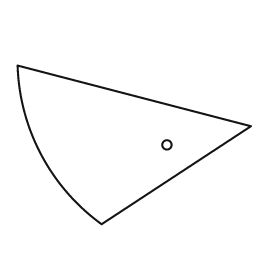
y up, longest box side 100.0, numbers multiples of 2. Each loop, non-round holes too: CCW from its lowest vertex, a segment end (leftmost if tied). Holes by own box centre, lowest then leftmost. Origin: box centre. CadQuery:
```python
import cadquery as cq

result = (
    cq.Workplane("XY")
    .moveTo(-14.0, -34.0)
    .lineTo(50.0, 8.0)
    .lineTo(-50.0, 34.0)
    .threePointArc((-40.0, -4.0), (-14.0, -34.0))
    .close()
    .moveTo(14.0, 0.0)
    .circle(2.0)
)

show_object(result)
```